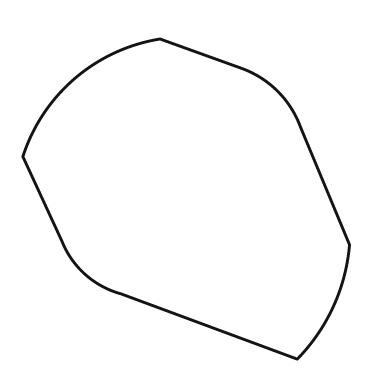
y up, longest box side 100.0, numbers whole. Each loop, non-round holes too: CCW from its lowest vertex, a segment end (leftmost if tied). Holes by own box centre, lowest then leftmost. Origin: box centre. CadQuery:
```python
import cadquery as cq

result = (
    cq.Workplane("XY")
    .moveTo(34.0, -49.0)
    .threePointArc((45.0, -33.0), (50.0, -14.0))
    .lineTo(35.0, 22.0)
    .threePointArc((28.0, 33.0), (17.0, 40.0))
    .lineTo(-8.0, 49.0)
    .threePointArc((-34.0, 37.0), (-50.0, 13.0))
    .lineTo(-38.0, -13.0)
    .threePointArc((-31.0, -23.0), (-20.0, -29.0))
    .close()
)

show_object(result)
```